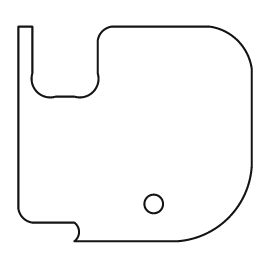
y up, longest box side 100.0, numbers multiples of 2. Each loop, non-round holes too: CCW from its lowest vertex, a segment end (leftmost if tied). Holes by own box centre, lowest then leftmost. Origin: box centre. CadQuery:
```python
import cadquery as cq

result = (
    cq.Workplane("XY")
    .moveTo(-26.0, -46.0)
    .lineTo(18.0, -46.0)
    .threePointArc((40.0, -36.0), (50.0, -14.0))
    .lineTo(50.0, 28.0)
    .threePointArc((44.0, 40.0), (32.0, 46.0))
    .lineTo(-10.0, 46.0)
    .threePointArc((-14.0, 44.0), (-16.0, 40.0))
    .lineTo(-16.0, 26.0)
    .threePointArc((-18.0, 18.0), (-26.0, 16.0))
    .lineTo(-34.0, 16.0)
    .threePointArc((-42.0, 18.0), (-44.0, 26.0))
    .lineTo(-44.0, 46.0)
    .lineTo(-50.0, 46.0)
    .lineTo(-50.0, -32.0)
    .threePointArc((-48.0, -36.0), (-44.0, -38.0))
    .lineTo(-26.0, -38.0)
    .threePointArc((-24.0, -42.0), (-26.0, -46.0))
    .close()
    .moveTo(8.0, -30.0)
    .circle(4.0)
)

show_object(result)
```